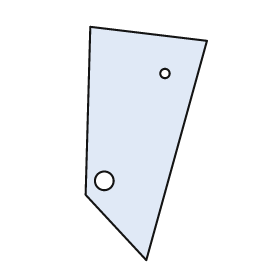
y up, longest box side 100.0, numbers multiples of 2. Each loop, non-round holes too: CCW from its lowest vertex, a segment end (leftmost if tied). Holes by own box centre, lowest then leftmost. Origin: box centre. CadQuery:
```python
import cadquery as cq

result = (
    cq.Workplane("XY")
    .moveTo(0.0, -50.0)
    .lineTo(26.0, 44.0)
    .lineTo(-24.0, 50.0)
    .lineTo(-26.0, -22.0)
    .close()
    .moveTo(-18.0, -16.0)
    .circle(4.0)
    .moveTo(8.0, 30.0)
    .circle(2.0)
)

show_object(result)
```